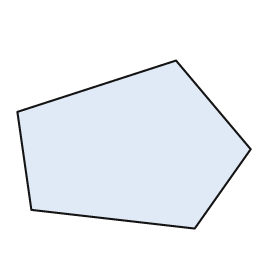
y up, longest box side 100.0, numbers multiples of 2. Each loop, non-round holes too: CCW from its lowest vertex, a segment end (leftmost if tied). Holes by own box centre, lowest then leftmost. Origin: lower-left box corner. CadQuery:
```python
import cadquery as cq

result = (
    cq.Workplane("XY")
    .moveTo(76.0, 0.0)
    .lineTo(100.0, 34.0)
    .lineTo(68.0, 72.0)
    .lineTo(0.0, 50.0)
    .lineTo(6.0, 8.0)
    .close()
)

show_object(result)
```